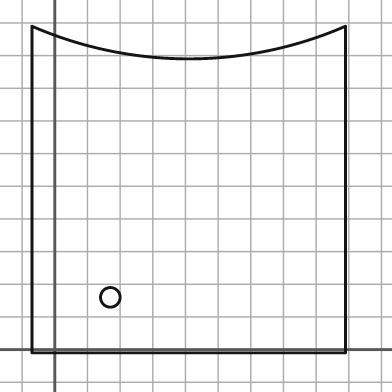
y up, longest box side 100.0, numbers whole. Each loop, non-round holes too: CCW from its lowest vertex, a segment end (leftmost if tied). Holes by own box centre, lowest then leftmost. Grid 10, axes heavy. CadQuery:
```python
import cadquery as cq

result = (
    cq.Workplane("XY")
    .moveTo(-7.0, -1.0)
    .lineTo(89.0, -1.0)
    .lineTo(89.0, 99.0)
    .threePointArc((41.0, 89.0), (-7.0, 99.0))
    .close()
    .moveTo(17.0, 16.0)
    .circle(3.0)
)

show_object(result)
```